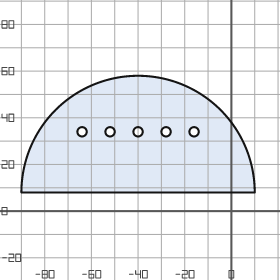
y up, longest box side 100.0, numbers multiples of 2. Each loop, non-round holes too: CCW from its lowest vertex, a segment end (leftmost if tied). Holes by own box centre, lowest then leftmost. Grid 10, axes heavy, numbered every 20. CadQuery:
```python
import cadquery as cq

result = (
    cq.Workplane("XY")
    .moveTo(-90.0, 8.0)
    .lineTo(10.0, 8.0)
    .threePointArc((-40.0, 58.0), (-90.0, 8.0))
    .close()
    .moveTo(-64.0, 34.0)
    .circle(2.0)
    .moveTo(-52.0, 34.0)
    .circle(2.0)
    .moveTo(-40.0, 34.0)
    .circle(2.0)
    .moveTo(-28.0, 34.0)
    .circle(2.0)
    .moveTo(-16.0, 34.0)
    .circle(2.0)
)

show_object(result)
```